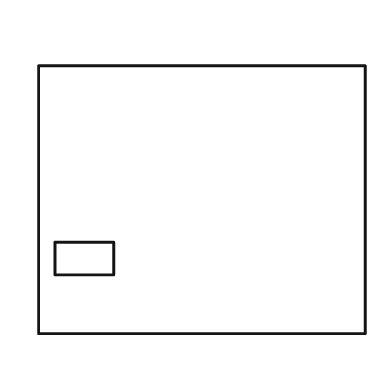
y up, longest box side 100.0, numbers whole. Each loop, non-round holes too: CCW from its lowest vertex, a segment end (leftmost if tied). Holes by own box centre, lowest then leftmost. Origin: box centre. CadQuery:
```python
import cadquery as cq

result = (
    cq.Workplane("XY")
    .moveTo(-50.0, -41.0)
    .lineTo(50.0, -41.0)
    .lineTo(50.0, 41.0)
    .lineTo(-50.0, 41.0)
    .close()
    .moveTo(-45.0, -23.0)
    .lineTo(-27.0, -23.0)
    .lineTo(-27.0, -13.0)
    .lineTo(-45.0, -13.0)
    .close()
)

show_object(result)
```